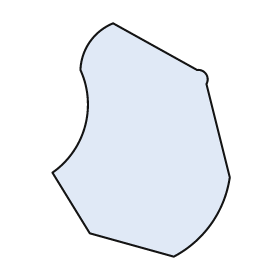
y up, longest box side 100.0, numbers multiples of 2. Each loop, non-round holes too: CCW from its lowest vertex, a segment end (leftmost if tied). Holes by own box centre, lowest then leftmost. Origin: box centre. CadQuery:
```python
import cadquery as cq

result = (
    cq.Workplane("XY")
    .moveTo(14.0, -50.0)
    .threePointArc((30.0, -36.0), (38.0, -16.0))
    .lineTo(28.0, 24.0)
    .threePointArc((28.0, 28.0), (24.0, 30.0))
    .lineTo(-12.0, 50.0)
    .threePointArc((-22.0, 42.0), (-26.0, 30.0))
    .threePointArc((-24.0, 6.0), (-38.0, -14.0))
    .lineTo(-22.0, -40.0)
    .close()
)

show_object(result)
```